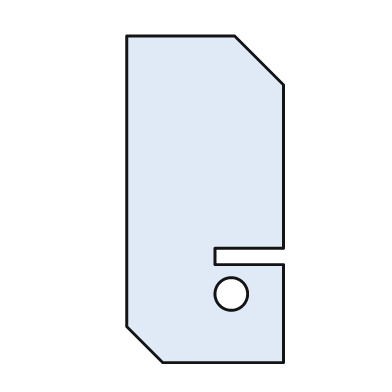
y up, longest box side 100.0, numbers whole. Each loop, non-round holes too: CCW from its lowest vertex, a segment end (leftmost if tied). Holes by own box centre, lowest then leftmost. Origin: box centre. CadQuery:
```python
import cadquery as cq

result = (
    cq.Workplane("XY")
    .moveTo(-13.0, -50.0)
    .lineTo(24.0, -50.0)
    .lineTo(24.0, -20.0)
    .lineTo(3.0, -20.0)
    .lineTo(3.0, -15.0)
    .lineTo(24.0, -15.0)
    .lineTo(24.0, 35.0)
    .lineTo(9.0, 50.0)
    .lineTo(-24.0, 50.0)
    .lineTo(-24.0, -39.0)
    .close()
    .moveTo(8.0, -29.0)
    .circle(5.0)
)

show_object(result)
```